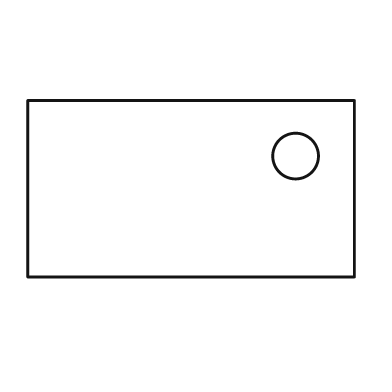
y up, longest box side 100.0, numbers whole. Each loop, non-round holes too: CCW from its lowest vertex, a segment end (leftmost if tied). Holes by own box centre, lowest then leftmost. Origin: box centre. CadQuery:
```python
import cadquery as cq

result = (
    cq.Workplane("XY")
    .moveTo(-50.0, -27.0)
    .lineTo(50.0, -27.0)
    .lineTo(50.0, 27.0)
    .lineTo(-50.0, 27.0)
    .close()
    .moveTo(32.0, 10.0)
    .circle(7.0)
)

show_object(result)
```